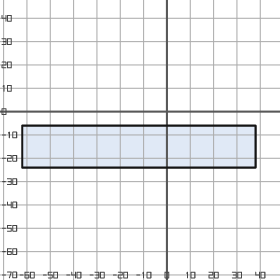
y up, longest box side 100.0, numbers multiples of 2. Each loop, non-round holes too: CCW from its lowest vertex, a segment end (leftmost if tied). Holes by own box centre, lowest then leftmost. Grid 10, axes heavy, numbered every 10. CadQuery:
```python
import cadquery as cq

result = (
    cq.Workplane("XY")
    .moveTo(-62.0, -24.0)
    .lineTo(38.0, -24.0)
    .lineTo(38.0, -6.0)
    .lineTo(-62.0, -6.0)
    .close()
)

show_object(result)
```